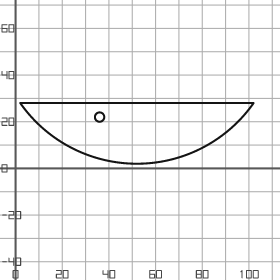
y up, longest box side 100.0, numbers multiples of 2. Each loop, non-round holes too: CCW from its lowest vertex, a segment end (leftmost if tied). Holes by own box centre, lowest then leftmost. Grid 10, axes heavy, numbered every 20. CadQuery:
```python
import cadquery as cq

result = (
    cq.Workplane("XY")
    .moveTo(2.0, 28.0)
    .threePointArc((52.0, 2.0), (102.0, 28.0))
    .close()
    .moveTo(36.0, 22.0)
    .circle(2.0)
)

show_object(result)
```